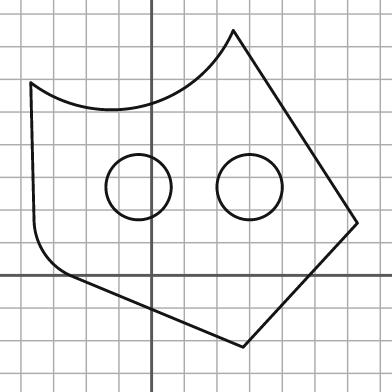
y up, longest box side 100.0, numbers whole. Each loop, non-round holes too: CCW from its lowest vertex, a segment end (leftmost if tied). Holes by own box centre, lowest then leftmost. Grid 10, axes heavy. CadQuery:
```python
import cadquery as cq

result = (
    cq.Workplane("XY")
    .moveTo(28.0, -22.0)
    .lineTo(63.0, 16.0)
    .lineTo(25.0, 75.0)
    .threePointArc((-2.0, 52.0), (-37.0, 59.0))
    .lineTo(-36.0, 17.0)
    .threePointArc((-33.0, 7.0), (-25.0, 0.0))
    .close()
    .moveTo(-4.0, 27.0)
    .circle(10.0)
    .moveTo(30.0, 27.0)
    .circle(10.0)
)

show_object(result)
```